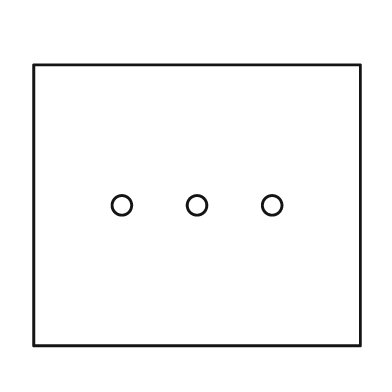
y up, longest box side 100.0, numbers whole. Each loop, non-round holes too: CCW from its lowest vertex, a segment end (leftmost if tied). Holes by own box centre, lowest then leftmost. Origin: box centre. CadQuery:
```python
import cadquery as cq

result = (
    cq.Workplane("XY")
    .moveTo(-50.0, -43.0)
    .lineTo(50.0, -43.0)
    .lineTo(50.0, 43.0)
    .lineTo(-50.0, 43.0)
    .close()
    .moveTo(-23.0, 0.0)
    .circle(3.0)
    .moveTo(0.0, 0.0)
    .circle(3.0)
    .moveTo(23.0, 0.0)
    .circle(3.0)
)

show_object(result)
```